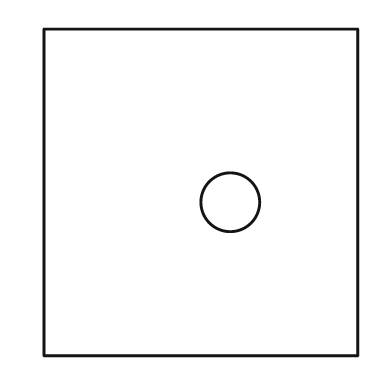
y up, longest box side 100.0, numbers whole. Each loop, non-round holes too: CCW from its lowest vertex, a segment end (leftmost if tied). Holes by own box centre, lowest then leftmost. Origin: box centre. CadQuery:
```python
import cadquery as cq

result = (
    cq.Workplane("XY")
    .moveTo(-48.0, -50.0)
    .lineTo(48.0, -50.0)
    .lineTo(48.0, 50.0)
    .lineTo(-48.0, 50.0)
    .close()
    .moveTo(9.0, -3.0)
    .circle(9.0)
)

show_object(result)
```